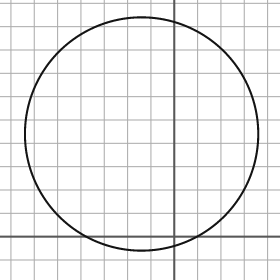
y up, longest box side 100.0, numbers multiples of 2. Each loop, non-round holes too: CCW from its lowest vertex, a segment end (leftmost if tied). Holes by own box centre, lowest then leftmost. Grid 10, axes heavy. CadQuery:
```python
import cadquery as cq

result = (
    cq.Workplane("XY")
    .moveTo(-14.0, 44.0)
    .circle(50.0)
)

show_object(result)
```